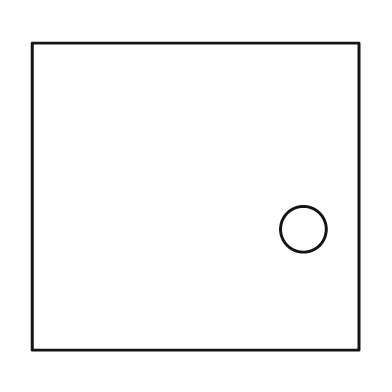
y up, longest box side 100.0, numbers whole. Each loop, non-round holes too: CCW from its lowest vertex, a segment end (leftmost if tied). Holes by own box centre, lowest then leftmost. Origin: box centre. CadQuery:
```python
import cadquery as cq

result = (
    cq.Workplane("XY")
    .moveTo(-50.0, -47.0)
    .lineTo(50.0, -47.0)
    .lineTo(50.0, 47.0)
    .lineTo(-50.0, 47.0)
    .close()
    .moveTo(33.0, -10.0)
    .circle(7.0)
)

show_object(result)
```